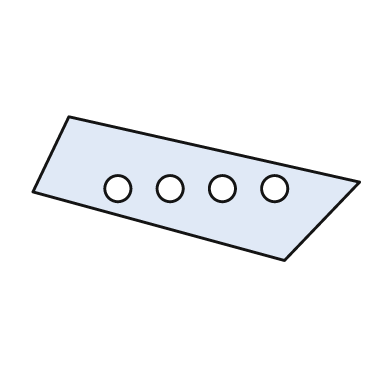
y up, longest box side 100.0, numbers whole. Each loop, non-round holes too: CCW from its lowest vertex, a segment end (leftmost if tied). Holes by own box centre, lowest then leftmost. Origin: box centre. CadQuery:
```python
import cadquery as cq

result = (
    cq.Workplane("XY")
    .moveTo(27.0, -22.0)
    .lineTo(50.0, 2.0)
    .lineTo(-39.0, 22.0)
    .lineTo(-50.0, -1.0)
    .close()
    .moveTo(-24.0, 0.0)
    .circle(4.0)
    .moveTo(-8.0, 0.0)
    .circle(4.0)
    .moveTo(8.0, 0.0)
    .circle(4.0)
    .moveTo(24.0, 0.0)
    .circle(4.0)
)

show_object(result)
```